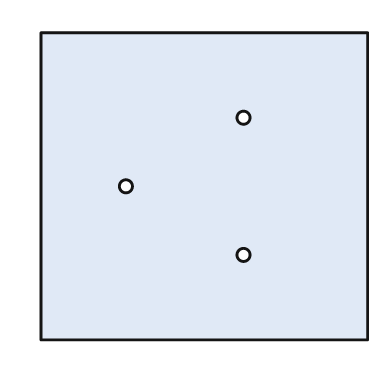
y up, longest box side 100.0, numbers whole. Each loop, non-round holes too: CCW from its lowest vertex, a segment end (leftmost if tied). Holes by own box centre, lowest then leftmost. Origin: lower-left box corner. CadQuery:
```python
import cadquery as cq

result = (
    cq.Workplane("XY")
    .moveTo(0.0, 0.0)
    .lineTo(100.0, 0.0)
    .lineTo(100.0, 94.0)
    .lineTo(0.0, 94.0)
    .close()
    .moveTo(62.0, 26.0)
    .circle(2.0)
    .moveTo(26.0, 47.0)
    .circle(2.0)
    .moveTo(62.0, 68.0)
    .circle(2.0)
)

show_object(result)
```